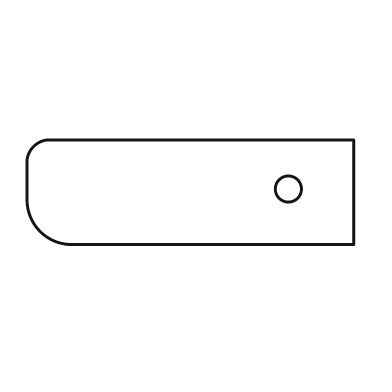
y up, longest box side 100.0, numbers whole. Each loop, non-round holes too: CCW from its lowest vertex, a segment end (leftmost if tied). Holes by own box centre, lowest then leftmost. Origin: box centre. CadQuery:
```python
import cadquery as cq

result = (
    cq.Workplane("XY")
    .moveTo(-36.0, -16.0)
    .lineTo(50.0, -16.0)
    .lineTo(50.0, 16.0)
    .lineTo(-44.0, 16.0)
    .threePointArc((-48.0, 14.0), (-50.0, 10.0))
    .lineTo(-50.0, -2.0)
    .threePointArc((-46.0, -12.0), (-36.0, -16.0))
    .close()
    .moveTo(30.0, 1.0)
    .circle(4.0)
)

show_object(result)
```